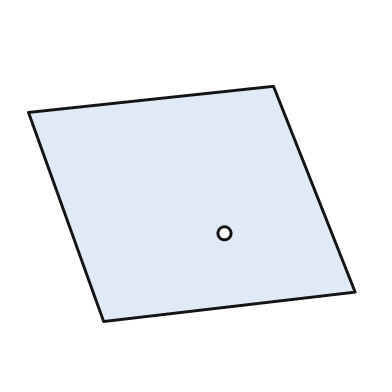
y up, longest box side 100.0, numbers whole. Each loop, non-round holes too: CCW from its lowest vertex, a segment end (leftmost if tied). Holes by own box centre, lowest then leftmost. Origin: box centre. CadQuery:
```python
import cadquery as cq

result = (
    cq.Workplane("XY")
    .moveTo(-27.0, -36.0)
    .lineTo(50.0, -27.0)
    .lineTo(25.0, 36.0)
    .lineTo(-50.0, 28.0)
    .close()
    .moveTo(10.0, -9.0)
    .circle(2.0)
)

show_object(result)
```